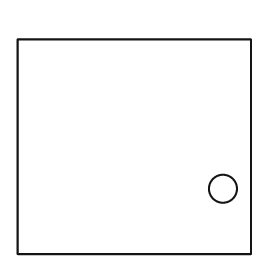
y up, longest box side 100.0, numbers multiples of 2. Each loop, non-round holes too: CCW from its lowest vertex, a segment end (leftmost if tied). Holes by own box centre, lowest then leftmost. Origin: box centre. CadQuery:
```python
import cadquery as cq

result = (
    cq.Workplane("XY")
    .moveTo(-50.0, -46.0)
    .lineTo(50.0, -46.0)
    .lineTo(50.0, 46.0)
    .lineTo(-50.0, 46.0)
    .close()
    .moveTo(38.0, -18.0)
    .circle(6.0)
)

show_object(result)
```